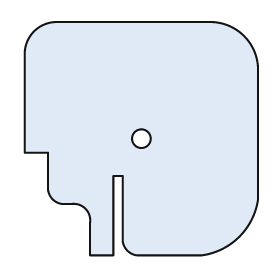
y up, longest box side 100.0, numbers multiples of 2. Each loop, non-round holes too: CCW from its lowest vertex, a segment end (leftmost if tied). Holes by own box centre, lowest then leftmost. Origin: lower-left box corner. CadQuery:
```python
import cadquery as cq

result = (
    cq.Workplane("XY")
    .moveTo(28.0, 0.0)
    .lineTo(38.0, 0.0)
    .lineTo(38.0, 34.0)
    .lineTo(42.0, 34.0)
    .lineTo(42.0, 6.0)
    .threePointArc((44.0, 2.0), (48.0, 0.0))
    .lineTo(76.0, 0.0)
    .threePointArc((92.0, 8.0), (100.0, 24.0))
    .lineTo(100.0, 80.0)
    .threePointArc((94.0, 94.0), (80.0, 100.0))
    .lineTo(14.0, 100.0)
    .threePointArc((4.0, 96.0), (0.0, 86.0))
    .lineTo(0.0, 44.0)
    .lineTo(10.0, 44.0)
    .lineTo(10.0, 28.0)
    .threePointArc((12.0, 24.0), (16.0, 22.0))
    .lineTo(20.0, 22.0)
    .threePointArc((26.0, 20.0), (28.0, 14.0))
    .close()
    .moveTo(50.0, 50.0)
    .circle(4.0)
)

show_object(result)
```